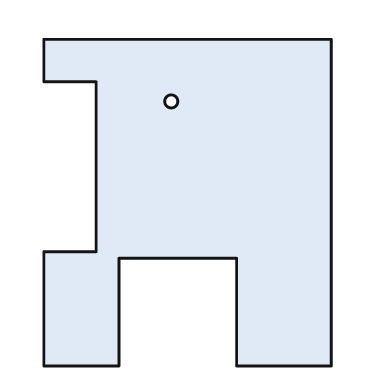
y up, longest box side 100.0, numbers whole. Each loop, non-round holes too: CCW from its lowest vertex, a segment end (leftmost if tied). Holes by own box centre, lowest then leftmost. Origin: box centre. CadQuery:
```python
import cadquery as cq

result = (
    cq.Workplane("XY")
    .moveTo(-44.0, -50.0)
    .lineTo(-21.0, -50.0)
    .lineTo(-21.0, -17.0)
    .lineTo(15.0, -17.0)
    .lineTo(15.0, -50.0)
    .lineTo(44.0, -50.0)
    .lineTo(44.0, 50.0)
    .lineTo(-44.0, 50.0)
    .lineTo(-44.0, 37.0)
    .lineTo(-28.0, 37.0)
    .lineTo(-28.0, -15.0)
    .lineTo(-44.0, -15.0)
    .close()
    .moveTo(-5.0, 31.0)
    .circle(2.0)
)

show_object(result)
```